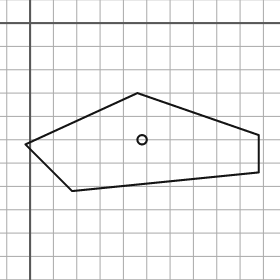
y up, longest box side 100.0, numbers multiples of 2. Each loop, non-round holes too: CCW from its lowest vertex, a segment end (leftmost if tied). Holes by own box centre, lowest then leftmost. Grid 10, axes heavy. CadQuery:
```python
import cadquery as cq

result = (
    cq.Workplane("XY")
    .moveTo(18.0, -72.0)
    .lineTo(98.0, -64.0)
    .lineTo(98.0, -48.0)
    .lineTo(46.0, -30.0)
    .lineTo(-2.0, -52.0)
    .close()
    .moveTo(48.0, -50.0)
    .circle(2.0)
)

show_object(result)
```